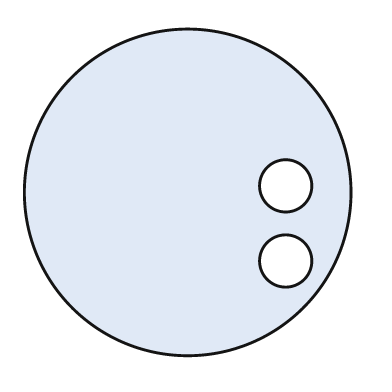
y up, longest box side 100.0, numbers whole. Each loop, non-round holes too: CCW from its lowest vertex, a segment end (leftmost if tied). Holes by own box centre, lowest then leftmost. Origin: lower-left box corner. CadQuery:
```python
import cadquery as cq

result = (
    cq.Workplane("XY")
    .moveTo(50.0, 50.0)
    .circle(50.0)
    .moveTo(80.0, 29.0)
    .circle(8.0)
    .moveTo(80.0, 52.0)
    .circle(8.0)
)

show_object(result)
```